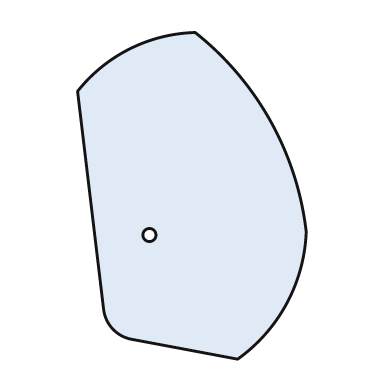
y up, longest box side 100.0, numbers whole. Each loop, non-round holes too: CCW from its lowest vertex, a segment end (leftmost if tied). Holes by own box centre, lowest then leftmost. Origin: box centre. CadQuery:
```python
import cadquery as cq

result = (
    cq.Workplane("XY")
    .moveTo(14.0, -50.0)
    .threePointArc((29.0, -33.0), (35.0, -11.0))
    .threePointArc((24.0, 23.0), (1.0, 50.0))
    .threePointArc((-19.0, 45.0), (-35.0, 32.0))
    .lineTo(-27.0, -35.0)
    .threePointArc((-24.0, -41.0), (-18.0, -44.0))
    .close()
    .moveTo(-13.0, -12.0)
    .circle(2.0)
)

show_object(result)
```